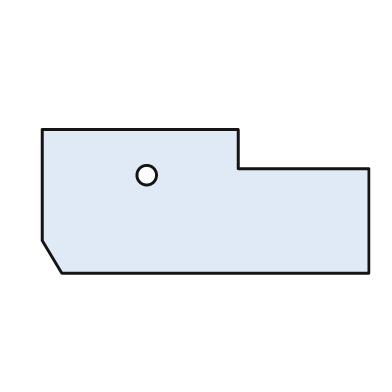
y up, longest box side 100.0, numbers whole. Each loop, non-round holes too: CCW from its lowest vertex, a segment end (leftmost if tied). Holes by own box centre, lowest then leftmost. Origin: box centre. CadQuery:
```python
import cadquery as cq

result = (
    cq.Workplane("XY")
    .moveTo(-44.0, -22.0)
    .lineTo(50.0, -22.0)
    .lineTo(50.0, 10.0)
    .lineTo(10.0, 10.0)
    .lineTo(10.0, 22.0)
    .lineTo(-50.0, 22.0)
    .lineTo(-50.0, -12.0)
    .close()
    .moveTo(-18.0, 8.0)
    .circle(3.0)
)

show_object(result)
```